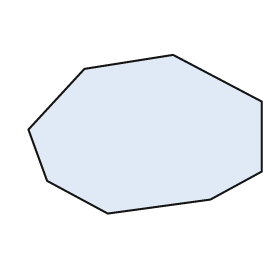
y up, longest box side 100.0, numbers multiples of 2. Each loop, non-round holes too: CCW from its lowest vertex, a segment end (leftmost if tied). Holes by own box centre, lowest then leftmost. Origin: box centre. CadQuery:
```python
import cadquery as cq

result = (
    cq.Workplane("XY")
    .moveTo(-16.0, -34.0)
    .lineTo(28.0, -28.0)
    .lineTo(50.0, -16.0)
    .lineTo(50.0, 14.0)
    .lineTo(12.0, 34.0)
    .lineTo(-26.0, 28.0)
    .lineTo(-50.0, 2.0)
    .lineTo(-42.0, -20.0)
    .close()
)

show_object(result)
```